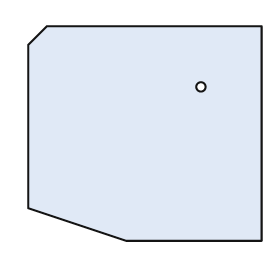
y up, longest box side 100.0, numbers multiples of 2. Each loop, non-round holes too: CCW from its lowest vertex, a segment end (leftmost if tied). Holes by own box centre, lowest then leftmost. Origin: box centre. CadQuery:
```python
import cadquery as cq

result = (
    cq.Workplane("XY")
    .moveTo(-8.0, -46.0)
    .lineTo(50.0, -46.0)
    .lineTo(50.0, 46.0)
    .lineTo(-42.0, 46.0)
    .lineTo(-50.0, 38.0)
    .lineTo(-50.0, -32.0)
    .close()
    .moveTo(24.0, 20.0)
    .circle(2.0)
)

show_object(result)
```